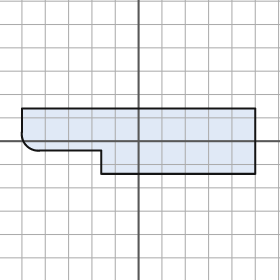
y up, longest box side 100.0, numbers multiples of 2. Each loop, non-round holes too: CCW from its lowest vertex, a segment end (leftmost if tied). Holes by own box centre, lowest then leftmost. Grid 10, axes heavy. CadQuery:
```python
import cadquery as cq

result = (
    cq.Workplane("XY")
    .moveTo(-16.0, -14.0)
    .lineTo(50.0, -14.0)
    .lineTo(50.0, 14.0)
    .lineTo(-50.0, 14.0)
    .lineTo(-50.0, 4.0)
    .threePointArc((-48.0, -2.0), (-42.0, -4.0))
    .lineTo(-16.0, -4.0)
    .close()
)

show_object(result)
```